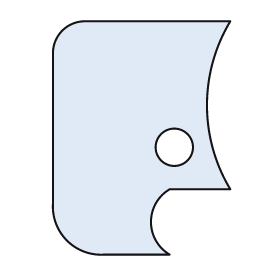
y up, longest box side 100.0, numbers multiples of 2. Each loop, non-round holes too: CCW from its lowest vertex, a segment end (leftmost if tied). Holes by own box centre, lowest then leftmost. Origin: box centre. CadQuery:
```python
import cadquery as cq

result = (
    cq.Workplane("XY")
    .moveTo(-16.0, -50.0)
    .lineTo(12.0, -50.0)
    .threePointArc((4.0, -36.0), (12.0, -22.0))
    .lineTo(38.0, -22.0)
    .threePointArc((28.0, 14.0), (38.0, 50.0))
    .lineTo(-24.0, 50.0)
    .threePointArc((-34.0, 46.0), (-38.0, 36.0))
    .lineTo(-38.0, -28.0)
    .threePointArc((-32.0, -44.0), (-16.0, -50.0))
    .close()
    .moveTo(14.0, -4.0)
    .circle(8.0)
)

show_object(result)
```